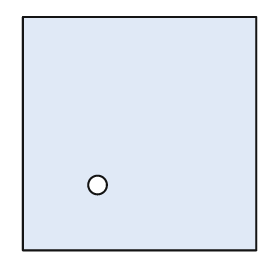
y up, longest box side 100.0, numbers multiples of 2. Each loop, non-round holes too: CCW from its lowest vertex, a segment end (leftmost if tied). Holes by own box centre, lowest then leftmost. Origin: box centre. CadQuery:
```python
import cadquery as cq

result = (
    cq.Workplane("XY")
    .moveTo(-50.0, -50.0)
    .lineTo(50.0, -50.0)
    .lineTo(50.0, 50.0)
    .lineTo(-50.0, 50.0)
    .close()
    .moveTo(-18.0, -22.0)
    .circle(4.0)
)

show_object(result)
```